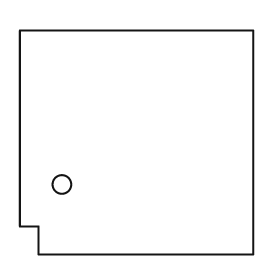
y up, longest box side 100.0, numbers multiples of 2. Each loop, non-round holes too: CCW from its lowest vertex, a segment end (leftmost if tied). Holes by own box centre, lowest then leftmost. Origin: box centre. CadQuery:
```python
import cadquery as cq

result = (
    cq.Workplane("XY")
    .moveTo(-42.0, -48.0)
    .lineTo(50.0, -48.0)
    .lineTo(50.0, 48.0)
    .lineTo(-50.0, 48.0)
    .lineTo(-50.0, -36.0)
    .lineTo(-42.0, -36.0)
    .close()
    .moveTo(-32.0, -18.0)
    .circle(4.0)
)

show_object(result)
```